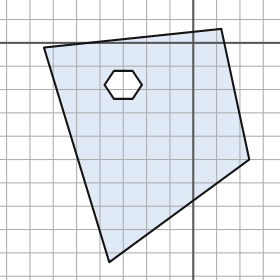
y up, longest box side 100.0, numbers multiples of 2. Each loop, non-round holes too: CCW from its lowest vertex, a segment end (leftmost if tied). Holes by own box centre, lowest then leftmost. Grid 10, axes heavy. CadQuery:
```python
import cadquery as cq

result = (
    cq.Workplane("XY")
    .moveTo(-36.0, -94.0)
    .lineTo(24.0, -50.0)
    .lineTo(12.0, 6.0)
    .lineTo(-64.0, -2.0)
    .close()
    .moveTo(-34.0, -24.0)
    .lineTo(-26.0, -24.0)
    .lineTo(-22.0, -18.0)
    .lineTo(-26.0, -12.0)
    .lineTo(-34.0, -12.0)
    .lineTo(-38.0, -18.0)
    .close()
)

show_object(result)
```